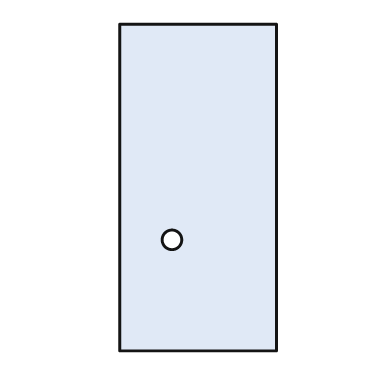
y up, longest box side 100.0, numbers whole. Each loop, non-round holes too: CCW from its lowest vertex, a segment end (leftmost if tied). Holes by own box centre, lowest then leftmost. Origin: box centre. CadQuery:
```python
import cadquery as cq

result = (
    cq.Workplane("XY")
    .moveTo(-24.0, -50.0)
    .lineTo(24.0, -50.0)
    .lineTo(24.0, 50.0)
    .lineTo(-24.0, 50.0)
    .close()
    .moveTo(-8.0, -16.0)
    .circle(3.0)
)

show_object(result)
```